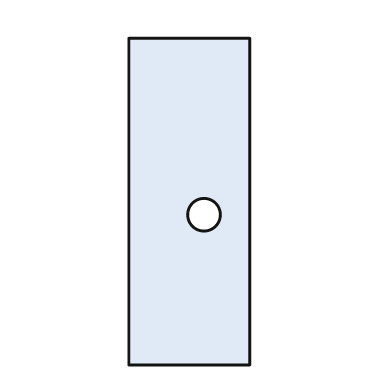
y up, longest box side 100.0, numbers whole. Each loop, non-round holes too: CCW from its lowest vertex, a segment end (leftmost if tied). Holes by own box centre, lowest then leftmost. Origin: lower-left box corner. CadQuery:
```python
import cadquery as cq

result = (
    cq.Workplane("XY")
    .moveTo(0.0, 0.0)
    .lineTo(37.0, 0.0)
    .lineTo(37.0, 100.0)
    .lineTo(0.0, 100.0)
    .close()
    .moveTo(23.0, 46.0)
    .circle(5.0)
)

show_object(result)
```